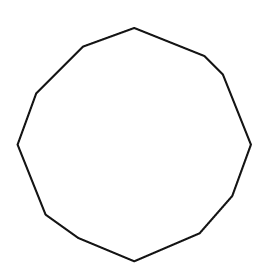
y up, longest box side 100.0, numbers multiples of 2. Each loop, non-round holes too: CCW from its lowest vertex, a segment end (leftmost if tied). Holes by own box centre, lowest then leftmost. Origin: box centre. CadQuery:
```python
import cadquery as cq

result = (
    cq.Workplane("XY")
    .moveTo(0.0, -50.0)
    .lineTo(28.0, -38.0)
    .lineTo(42.0, -22.0)
    .lineTo(50.0, 0.0)
    .lineTo(38.0, 30.0)
    .lineTo(30.0, 38.0)
    .lineTo(0.0, 50.0)
    .lineTo(-22.0, 42.0)
    .lineTo(-42.0, 22.0)
    .lineTo(-50.0, 0.0)
    .lineTo(-38.0, -30.0)
    .lineTo(-24.0, -40.0)
    .close()
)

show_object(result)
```